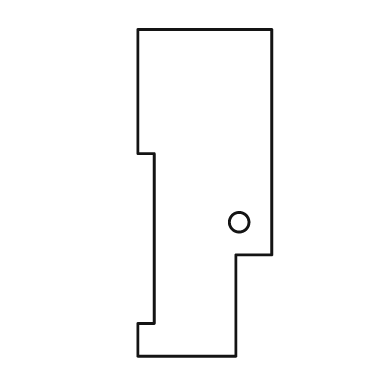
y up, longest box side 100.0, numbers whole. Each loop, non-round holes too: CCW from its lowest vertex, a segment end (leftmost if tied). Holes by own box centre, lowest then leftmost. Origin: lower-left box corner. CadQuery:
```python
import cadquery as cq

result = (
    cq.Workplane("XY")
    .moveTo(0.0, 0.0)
    .lineTo(30.0, 0.0)
    .lineTo(30.0, 31.0)
    .lineTo(41.0, 31.0)
    .lineTo(41.0, 100.0)
    .lineTo(0.0, 100.0)
    .lineTo(0.0, 62.0)
    .lineTo(5.0, 62.0)
    .lineTo(5.0, 10.0)
    .lineTo(0.0, 10.0)
    .close()
    .moveTo(31.0, 41.0)
    .circle(3.0)
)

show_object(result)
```